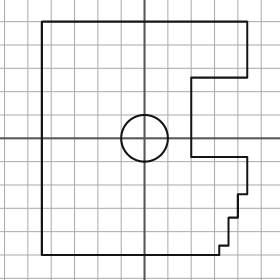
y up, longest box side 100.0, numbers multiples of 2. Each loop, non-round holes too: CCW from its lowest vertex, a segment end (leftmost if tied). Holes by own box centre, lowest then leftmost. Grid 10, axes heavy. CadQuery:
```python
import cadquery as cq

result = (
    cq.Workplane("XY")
    .moveTo(-44.0, -50.0)
    .lineTo(32.0, -50.0)
    .lineTo(32.0, -46.0)
    .lineTo(36.0, -46.0)
    .lineTo(36.0, -34.0)
    .lineTo(40.0, -34.0)
    .lineTo(40.0, -24.0)
    .lineTo(44.0, -24.0)
    .lineTo(44.0, -8.0)
    .lineTo(20.0, -8.0)
    .lineTo(20.0, 26.0)
    .lineTo(44.0, 26.0)
    .lineTo(44.0, 50.0)
    .lineTo(-44.0, 50.0)
    .close()
    .moveTo(0.0, 0.0)
    .circle(10.0)
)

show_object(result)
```